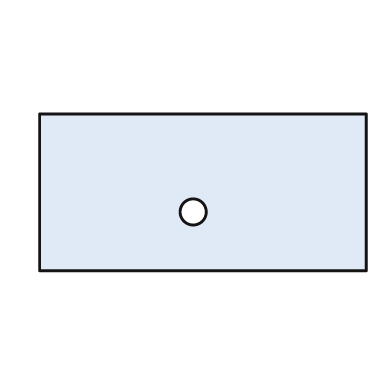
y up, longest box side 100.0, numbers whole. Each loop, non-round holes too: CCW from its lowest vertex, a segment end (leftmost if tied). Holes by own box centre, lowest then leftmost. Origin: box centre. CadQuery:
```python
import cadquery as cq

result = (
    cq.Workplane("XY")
    .moveTo(-50.0, -24.0)
    .lineTo(50.0, -24.0)
    .lineTo(50.0, 24.0)
    .lineTo(-50.0, 24.0)
    .close()
    .moveTo(-3.0, -6.0)
    .circle(4.0)
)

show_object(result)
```